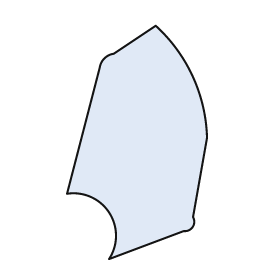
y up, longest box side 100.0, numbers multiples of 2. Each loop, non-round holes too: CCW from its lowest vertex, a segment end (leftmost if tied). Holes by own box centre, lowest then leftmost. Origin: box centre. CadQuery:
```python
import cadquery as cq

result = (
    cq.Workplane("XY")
    .moveTo(-12.0, -50.0)
    .lineTo(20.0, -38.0)
    .threePointArc((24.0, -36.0), (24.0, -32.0))
    .lineTo(30.0, 2.0)
    .threePointArc((24.0, 28.0), (8.0, 50.0))
    .lineTo(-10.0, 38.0)
    .threePointArc((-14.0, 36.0), (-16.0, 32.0))
    .lineTo(-30.0, -22.0)
    .threePointArc((-12.0, -30.0), (-12.0, -50.0))
    .close()
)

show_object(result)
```